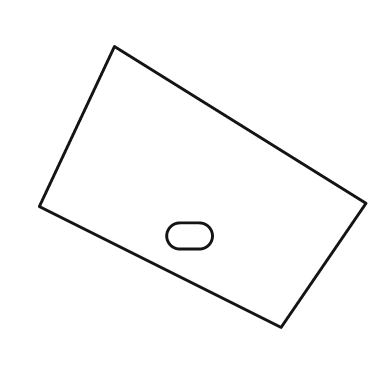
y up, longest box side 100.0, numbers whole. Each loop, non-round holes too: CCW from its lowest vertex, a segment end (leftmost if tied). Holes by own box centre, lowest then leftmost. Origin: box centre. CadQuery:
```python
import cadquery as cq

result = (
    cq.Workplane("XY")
    .moveTo(24.0, -43.0)
    .lineTo(50.0, -5.0)
    .lineTo(-27.0, 43.0)
    .lineTo(-50.0, -6.0)
    .close()
    .moveTo(-7.0, -19.0)
    .lineTo(-1.0, -19.0)
    .threePointArc((3.0, -15.0), (-1.0, -11.0))
    .lineTo(-7.0, -11.0)
    .threePointArc((-11.0, -15.0), (-7.0, -19.0))
    .close()
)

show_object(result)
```